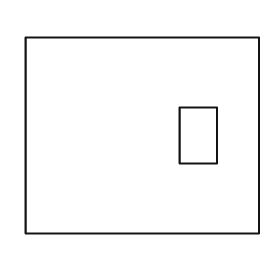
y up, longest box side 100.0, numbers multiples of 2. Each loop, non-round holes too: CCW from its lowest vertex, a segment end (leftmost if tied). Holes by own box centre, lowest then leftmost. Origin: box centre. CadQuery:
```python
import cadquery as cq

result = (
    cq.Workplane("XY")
    .moveTo(-50.0, -42.0)
    .lineTo(50.0, -42.0)
    .lineTo(50.0, 42.0)
    .lineTo(-50.0, 42.0)
    .close()
    .moveTo(16.0, -12.0)
    .lineTo(32.0, -12.0)
    .lineTo(32.0, 12.0)
    .lineTo(16.0, 12.0)
    .close()
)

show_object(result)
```